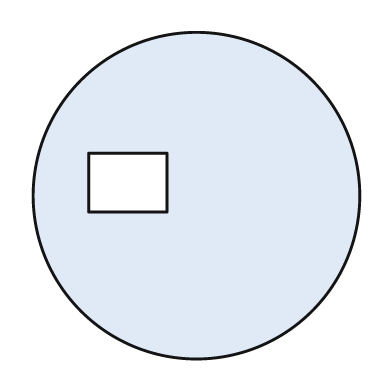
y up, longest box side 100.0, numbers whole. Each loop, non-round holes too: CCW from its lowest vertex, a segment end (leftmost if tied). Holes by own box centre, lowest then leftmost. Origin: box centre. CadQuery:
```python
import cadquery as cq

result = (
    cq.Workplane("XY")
    .moveTo(0.0, 0.0)
    .circle(50.0)
    .moveTo(-33.0, -5.0)
    .lineTo(-9.0, -5.0)
    .lineTo(-9.0, 13.0)
    .lineTo(-33.0, 13.0)
    .close()
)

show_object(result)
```